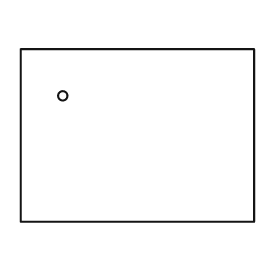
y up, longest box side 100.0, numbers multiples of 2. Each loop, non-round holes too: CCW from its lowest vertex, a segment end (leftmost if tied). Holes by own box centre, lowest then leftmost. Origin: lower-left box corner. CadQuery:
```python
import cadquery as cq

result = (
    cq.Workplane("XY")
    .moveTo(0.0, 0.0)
    .lineTo(100.0, 0.0)
    .lineTo(100.0, 74.0)
    .lineTo(0.0, 74.0)
    .close()
    .moveTo(18.0, 54.0)
    .circle(2.0)
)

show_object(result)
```